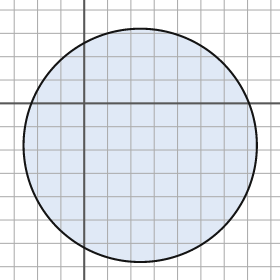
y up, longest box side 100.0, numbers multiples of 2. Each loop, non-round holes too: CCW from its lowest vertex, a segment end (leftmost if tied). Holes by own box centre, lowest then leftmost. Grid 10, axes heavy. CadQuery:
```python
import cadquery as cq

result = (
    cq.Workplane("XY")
    .moveTo(24.0, -18.0)
    .circle(50.0)
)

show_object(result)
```